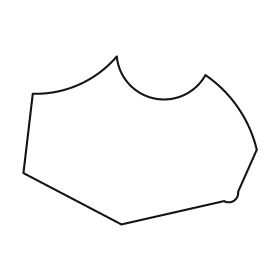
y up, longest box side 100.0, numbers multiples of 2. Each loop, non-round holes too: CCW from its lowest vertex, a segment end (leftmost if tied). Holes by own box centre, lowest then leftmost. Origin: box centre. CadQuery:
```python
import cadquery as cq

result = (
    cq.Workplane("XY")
    .moveTo(-8.0, -36.0)
    .lineTo(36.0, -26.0)
    .threePointArc((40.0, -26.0), (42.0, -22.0))
    .lineTo(50.0, -4.0)
    .threePointArc((42.0, 14.0), (28.0, 28.0))
    .threePointArc((6.0, 18.0), (-10.0, 36.0))
    .threePointArc((-26.0, 24.0), (-46.0, 20.0))
    .lineTo(-50.0, -14.0)
    .close()
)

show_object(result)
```